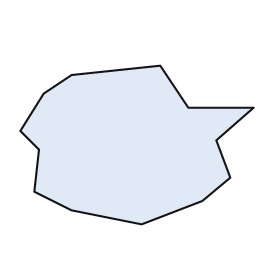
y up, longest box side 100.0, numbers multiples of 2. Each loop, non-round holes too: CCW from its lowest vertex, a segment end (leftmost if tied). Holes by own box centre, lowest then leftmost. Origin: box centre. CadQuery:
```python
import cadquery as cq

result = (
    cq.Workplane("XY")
    .moveTo(2.0, -34.0)
    .lineTo(28.0, -24.0)
    .lineTo(40.0, -14.0)
    .lineTo(34.0, 2.0)
    .lineTo(50.0, 16.0)
    .lineTo(22.0, 16.0)
    .lineTo(10.0, 34.0)
    .lineTo(-28.0, 30.0)
    .lineTo(-40.0, 22.0)
    .lineTo(-50.0, 6.0)
    .lineTo(-42.0, -2.0)
    .lineTo(-44.0, -20.0)
    .lineTo(-28.0, -28.0)
    .close()
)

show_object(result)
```